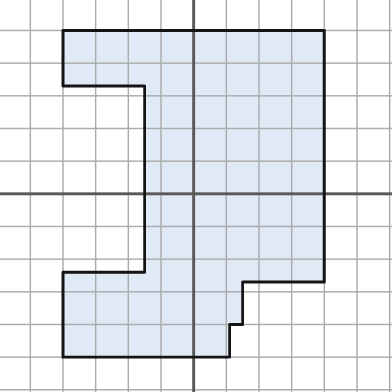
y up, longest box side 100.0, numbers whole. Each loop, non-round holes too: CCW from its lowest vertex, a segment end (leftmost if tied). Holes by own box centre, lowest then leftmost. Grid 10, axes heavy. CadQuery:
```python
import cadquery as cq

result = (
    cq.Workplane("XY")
    .moveTo(-40.0, -50.0)
    .lineTo(11.0, -50.0)
    .lineTo(11.0, -40.0)
    .lineTo(15.0, -40.0)
    .lineTo(15.0, -27.0)
    .lineTo(40.0, -27.0)
    .lineTo(40.0, 50.0)
    .lineTo(-40.0, 50.0)
    .lineTo(-40.0, 33.0)
    .lineTo(-15.0, 33.0)
    .lineTo(-15.0, -24.0)
    .lineTo(-40.0, -24.0)
    .close()
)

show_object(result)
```